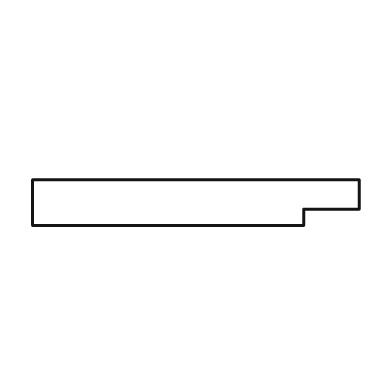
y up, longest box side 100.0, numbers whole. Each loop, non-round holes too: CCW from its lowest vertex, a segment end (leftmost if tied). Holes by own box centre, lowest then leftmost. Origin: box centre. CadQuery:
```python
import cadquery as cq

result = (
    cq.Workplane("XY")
    .moveTo(-50.0, -7.0)
    .lineTo(33.0, -7.0)
    .lineTo(33.0, -2.0)
    .lineTo(50.0, -2.0)
    .lineTo(50.0, 7.0)
    .lineTo(-50.0, 7.0)
    .close()
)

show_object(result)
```